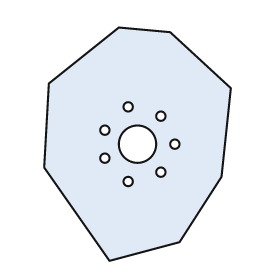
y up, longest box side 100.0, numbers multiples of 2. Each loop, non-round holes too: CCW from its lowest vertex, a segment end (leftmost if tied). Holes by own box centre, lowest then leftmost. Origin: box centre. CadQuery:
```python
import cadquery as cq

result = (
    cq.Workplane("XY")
    .moveTo(-12.0, -50.0)
    .lineTo(18.0, -42.0)
    .lineTo(36.0, -14.0)
    .lineTo(40.0, 24.0)
    .lineTo(14.0, 48.0)
    .lineTo(-8.0, 50.0)
    .lineTo(-38.0, 26.0)
    .lineTo(-40.0, -10.0)
    .close()
    .moveTo(-4.0, -16.0)
    .circle(2.0)
    .moveTo(10.0, -12.0)
    .circle(2.0)
    .moveTo(-14.0, -6.0)
    .circle(2.0)
    .moveTo(0.0, 0.0)
    .circle(8.0)
    .moveTo(16.0, 0.0)
    .circle(2.0)
    .moveTo(-14.0, 6.0)
    .circle(2.0)
    .moveTo(10.0, 12.0)
    .circle(2.0)
    .moveTo(-4.0, 16.0)
    .circle(2.0)
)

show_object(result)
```